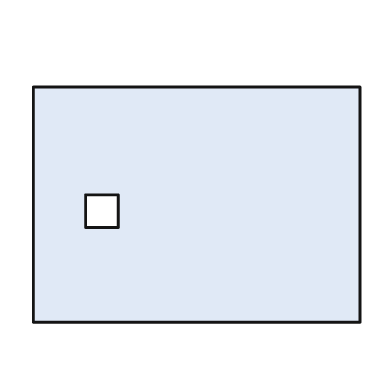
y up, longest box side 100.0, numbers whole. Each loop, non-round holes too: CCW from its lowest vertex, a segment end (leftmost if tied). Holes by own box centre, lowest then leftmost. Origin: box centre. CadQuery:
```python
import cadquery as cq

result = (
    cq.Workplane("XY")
    .moveTo(-50.0, -36.0)
    .lineTo(50.0, -36.0)
    .lineTo(50.0, 36.0)
    .lineTo(-50.0, 36.0)
    .close()
    .moveTo(-34.0, -7.0)
    .lineTo(-24.0, -7.0)
    .lineTo(-24.0, 3.0)
    .lineTo(-34.0, 3.0)
    .close()
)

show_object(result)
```